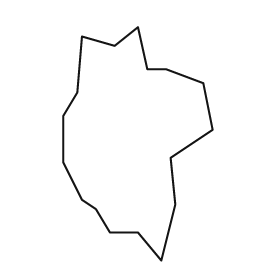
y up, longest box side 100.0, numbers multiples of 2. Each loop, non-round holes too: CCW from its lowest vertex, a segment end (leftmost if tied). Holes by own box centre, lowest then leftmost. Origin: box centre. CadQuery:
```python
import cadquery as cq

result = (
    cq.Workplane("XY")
    .moveTo(10.0, -50.0)
    .lineTo(16.0, -26.0)
    .lineTo(14.0, -6.0)
    .lineTo(32.0, 6.0)
    .lineTo(28.0, 26.0)
    .lineTo(12.0, 32.0)
    .lineTo(4.0, 32.0)
    .lineTo(0.0, 50.0)
    .lineTo(-10.0, 42.0)
    .lineTo(-24.0, 46.0)
    .lineTo(-26.0, 22.0)
    .lineTo(-32.0, 12.0)
    .lineTo(-32.0, -8.0)
    .lineTo(-24.0, -24.0)
    .lineTo(-18.0, -28.0)
    .lineTo(-12.0, -38.0)
    .lineTo(0.0, -38.0)
    .close()
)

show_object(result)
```